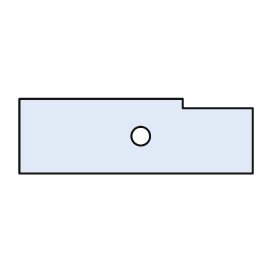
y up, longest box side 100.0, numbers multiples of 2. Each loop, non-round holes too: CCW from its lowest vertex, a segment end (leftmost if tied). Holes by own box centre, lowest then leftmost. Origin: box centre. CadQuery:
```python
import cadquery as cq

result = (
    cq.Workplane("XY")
    .moveTo(-50.0, -16.0)
    .lineTo(50.0, -16.0)
    .lineTo(50.0, 12.0)
    .lineTo(20.0, 12.0)
    .lineTo(20.0, 16.0)
    .lineTo(-50.0, 16.0)
    .close()
    .moveTo(2.0, 0.0)
    .circle(4.0)
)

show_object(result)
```